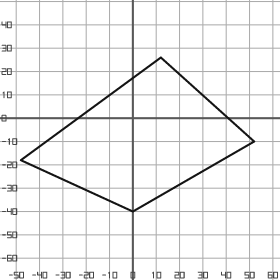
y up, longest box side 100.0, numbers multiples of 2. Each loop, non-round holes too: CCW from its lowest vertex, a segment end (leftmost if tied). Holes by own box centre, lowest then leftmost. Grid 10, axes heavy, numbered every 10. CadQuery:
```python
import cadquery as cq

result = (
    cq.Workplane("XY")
    .moveTo(0.0, -40.0)
    .lineTo(52.0, -10.0)
    .lineTo(12.0, 26.0)
    .lineTo(-48.0, -18.0)
    .close()
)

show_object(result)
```